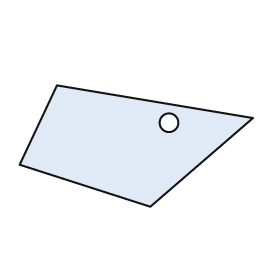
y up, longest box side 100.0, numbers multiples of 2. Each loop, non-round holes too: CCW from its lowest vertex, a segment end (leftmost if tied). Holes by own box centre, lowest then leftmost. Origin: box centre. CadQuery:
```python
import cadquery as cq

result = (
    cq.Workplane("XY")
    .moveTo(6.0, -26.0)
    .lineTo(50.0, 12.0)
    .lineTo(-34.0, 26.0)
    .lineTo(-50.0, -8.0)
    .close()
    .moveTo(14.0, 10.0)
    .circle(4.0)
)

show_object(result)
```